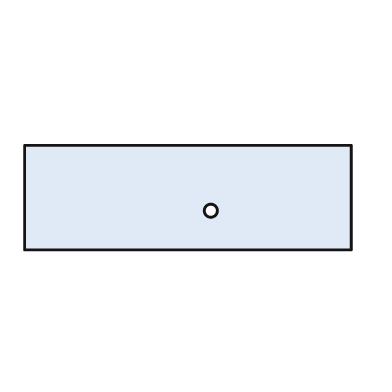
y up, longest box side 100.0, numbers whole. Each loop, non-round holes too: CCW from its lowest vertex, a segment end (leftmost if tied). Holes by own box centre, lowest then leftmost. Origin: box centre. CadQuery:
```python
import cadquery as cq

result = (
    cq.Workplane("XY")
    .moveTo(-50.0, -16.0)
    .lineTo(50.0, -16.0)
    .lineTo(50.0, 16.0)
    .lineTo(-50.0, 16.0)
    .close()
    .moveTo(7.0, -4.0)
    .circle(2.0)
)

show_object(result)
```